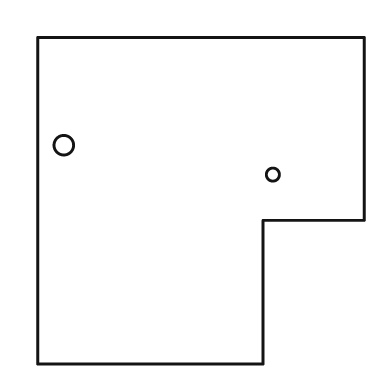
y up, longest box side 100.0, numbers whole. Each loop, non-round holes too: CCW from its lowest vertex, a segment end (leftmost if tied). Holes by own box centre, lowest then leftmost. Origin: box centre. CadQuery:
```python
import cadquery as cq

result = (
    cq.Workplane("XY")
    .moveTo(-50.0, -50.0)
    .lineTo(19.0, -50.0)
    .lineTo(19.0, -6.0)
    .lineTo(50.0, -6.0)
    .lineTo(50.0, 50.0)
    .lineTo(-50.0, 50.0)
    .close()
    .moveTo(22.0, 8.0)
    .circle(2.0)
    .moveTo(-42.0, 17.0)
    .circle(3.0)
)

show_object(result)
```